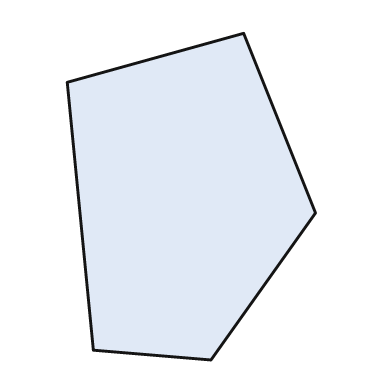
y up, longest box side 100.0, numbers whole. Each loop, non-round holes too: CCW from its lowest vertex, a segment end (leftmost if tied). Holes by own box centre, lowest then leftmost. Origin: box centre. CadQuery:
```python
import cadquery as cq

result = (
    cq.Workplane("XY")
    .moveTo(6.0, -50.0)
    .lineTo(38.0, -5.0)
    .lineTo(16.0, 50.0)
    .lineTo(-38.0, 35.0)
    .lineTo(-30.0, -47.0)
    .close()
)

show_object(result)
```